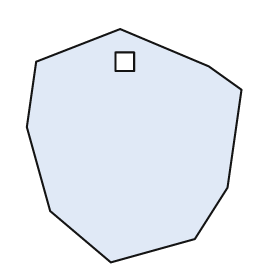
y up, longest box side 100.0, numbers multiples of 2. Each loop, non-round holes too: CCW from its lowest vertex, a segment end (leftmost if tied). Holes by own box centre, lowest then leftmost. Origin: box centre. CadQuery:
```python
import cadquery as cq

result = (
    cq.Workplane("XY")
    .moveTo(-10.0, -50.0)
    .lineTo(26.0, -40.0)
    .lineTo(40.0, -18.0)
    .lineTo(46.0, 24.0)
    .lineTo(32.0, 34.0)
    .lineTo(-6.0, 50.0)
    .lineTo(-42.0, 36.0)
    .lineTo(-46.0, 8.0)
    .lineTo(-36.0, -28.0)
    .close()
    .moveTo(-8.0, 32.0)
    .lineTo(0.0, 32.0)
    .lineTo(0.0, 40.0)
    .lineTo(-8.0, 40.0)
    .close()
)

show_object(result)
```